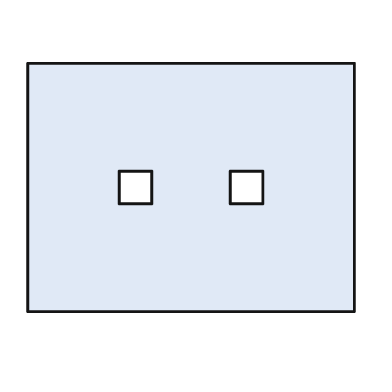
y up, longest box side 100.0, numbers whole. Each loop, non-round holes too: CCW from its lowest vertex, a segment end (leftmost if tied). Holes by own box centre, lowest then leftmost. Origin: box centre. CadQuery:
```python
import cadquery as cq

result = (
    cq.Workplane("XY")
    .moveTo(-50.0, -38.0)
    .lineTo(50.0, -38.0)
    .lineTo(50.0, 38.0)
    .lineTo(-50.0, 38.0)
    .close()
    .moveTo(-22.0, -5.0)
    .lineTo(-12.0, -5.0)
    .lineTo(-12.0, 5.0)
    .lineTo(-22.0, 5.0)
    .close()
    .moveTo(12.0, -5.0)
    .lineTo(22.0, -5.0)
    .lineTo(22.0, 5.0)
    .lineTo(12.0, 5.0)
    .close()
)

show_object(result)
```